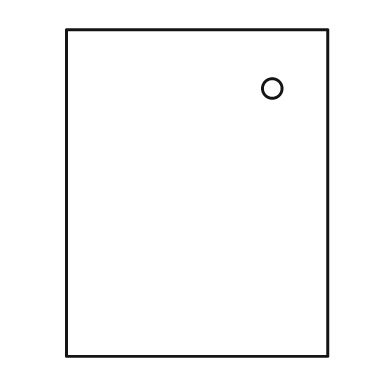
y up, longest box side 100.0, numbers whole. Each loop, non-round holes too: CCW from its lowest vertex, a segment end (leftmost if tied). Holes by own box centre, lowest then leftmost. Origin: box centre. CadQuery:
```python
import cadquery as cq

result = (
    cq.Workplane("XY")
    .moveTo(-40.0, -50.0)
    .lineTo(40.0, -50.0)
    .lineTo(40.0, 50.0)
    .lineTo(-40.0, 50.0)
    .close()
    .moveTo(23.0, 32.0)
    .circle(3.0)
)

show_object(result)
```